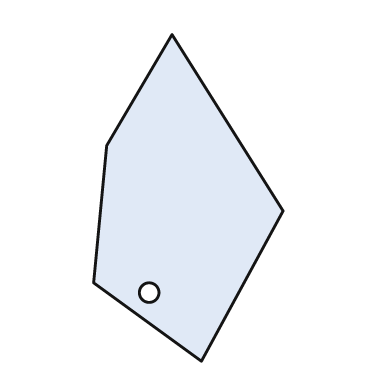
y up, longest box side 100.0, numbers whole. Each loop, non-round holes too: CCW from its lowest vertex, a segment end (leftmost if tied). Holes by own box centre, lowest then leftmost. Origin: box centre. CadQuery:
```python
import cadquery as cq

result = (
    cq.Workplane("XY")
    .moveTo(4.0, -50.0)
    .lineTo(29.0, -4.0)
    .lineTo(-5.0, 50.0)
    .lineTo(-25.0, 16.0)
    .lineTo(-29.0, -26.0)
    .close()
    .moveTo(-12.0, -29.0)
    .circle(3.0)
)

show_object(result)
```